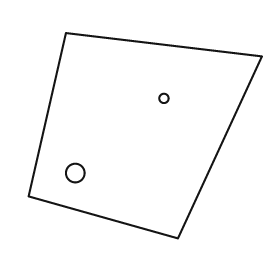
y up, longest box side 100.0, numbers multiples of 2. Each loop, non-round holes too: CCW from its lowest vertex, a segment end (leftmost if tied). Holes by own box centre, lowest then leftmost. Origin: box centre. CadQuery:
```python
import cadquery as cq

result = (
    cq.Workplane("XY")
    .moveTo(14.0, -44.0)
    .lineTo(50.0, 34.0)
    .lineTo(-34.0, 44.0)
    .lineTo(-50.0, -26.0)
    .close()
    .moveTo(-30.0, -16.0)
    .circle(4.0)
    .moveTo(8.0, 16.0)
    .circle(2.0)
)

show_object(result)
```